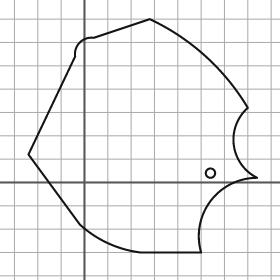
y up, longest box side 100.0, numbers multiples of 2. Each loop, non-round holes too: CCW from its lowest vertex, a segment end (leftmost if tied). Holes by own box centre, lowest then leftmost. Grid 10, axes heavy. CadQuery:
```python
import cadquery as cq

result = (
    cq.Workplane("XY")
    .moveTo(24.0, -30.0)
    .lineTo(50.0, -30.0)
    .threePointArc((54.0, -8.0), (74.0, 2.0))
    .threePointArc((64.0, 16.0), (70.0, 32.0))
    .threePointArc((52.0, 54.0), (28.0, 70.0))
    .lineTo(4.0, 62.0)
    .threePointArc((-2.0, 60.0), (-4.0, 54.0))
    .lineTo(-24.0, 12.0)
    .lineTo(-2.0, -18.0)
    .threePointArc((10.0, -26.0), (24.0, -30.0))
    .close()
    .moveTo(54.0, 4.0)
    .circle(2.0)
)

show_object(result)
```